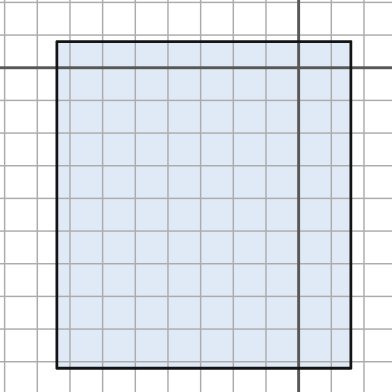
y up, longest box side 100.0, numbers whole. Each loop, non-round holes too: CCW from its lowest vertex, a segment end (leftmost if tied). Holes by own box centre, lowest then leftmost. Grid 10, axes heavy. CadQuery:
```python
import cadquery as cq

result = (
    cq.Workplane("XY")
    .moveTo(-74.0, -92.0)
    .lineTo(16.0, -92.0)
    .lineTo(16.0, 8.0)
    .lineTo(-74.0, 8.0)
    .close()
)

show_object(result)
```